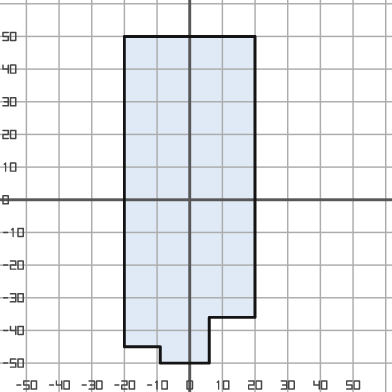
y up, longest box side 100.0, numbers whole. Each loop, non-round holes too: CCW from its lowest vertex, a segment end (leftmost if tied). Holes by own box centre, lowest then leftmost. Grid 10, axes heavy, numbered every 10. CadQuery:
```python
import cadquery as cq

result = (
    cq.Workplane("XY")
    .moveTo(-9.0, -50.0)
    .lineTo(6.0, -50.0)
    .lineTo(6.0, -36.0)
    .lineTo(20.0, -36.0)
    .lineTo(20.0, 50.0)
    .lineTo(-20.0, 50.0)
    .lineTo(-20.0, -45.0)
    .lineTo(-9.0, -45.0)
    .close()
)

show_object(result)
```